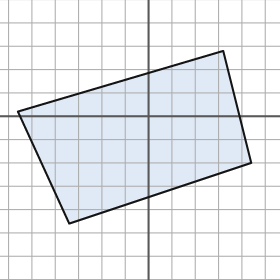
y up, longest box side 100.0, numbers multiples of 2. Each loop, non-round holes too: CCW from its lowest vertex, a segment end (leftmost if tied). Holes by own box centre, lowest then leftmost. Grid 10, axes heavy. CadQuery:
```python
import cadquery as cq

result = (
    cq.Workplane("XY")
    .moveTo(-34.0, -46.0)
    .lineTo(44.0, -20.0)
    .lineTo(32.0, 28.0)
    .lineTo(-56.0, 2.0)
    .close()
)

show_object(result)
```